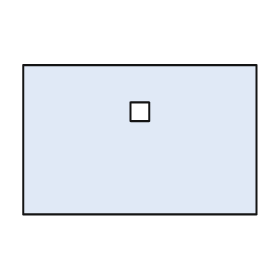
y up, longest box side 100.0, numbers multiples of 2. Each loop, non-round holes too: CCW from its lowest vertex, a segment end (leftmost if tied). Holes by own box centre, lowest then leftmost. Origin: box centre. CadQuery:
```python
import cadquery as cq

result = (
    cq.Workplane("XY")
    .moveTo(-50.0, -32.0)
    .lineTo(50.0, -32.0)
    .lineTo(50.0, 32.0)
    .lineTo(-50.0, 32.0)
    .close()
    .moveTo(-4.0, 8.0)
    .lineTo(4.0, 8.0)
    .lineTo(4.0, 16.0)
    .lineTo(-4.0, 16.0)
    .close()
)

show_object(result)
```